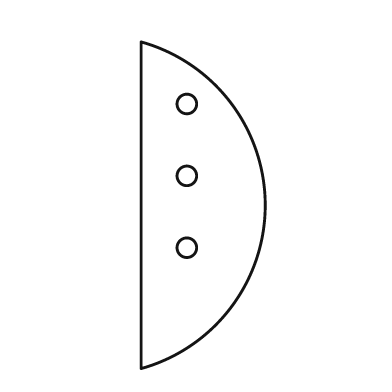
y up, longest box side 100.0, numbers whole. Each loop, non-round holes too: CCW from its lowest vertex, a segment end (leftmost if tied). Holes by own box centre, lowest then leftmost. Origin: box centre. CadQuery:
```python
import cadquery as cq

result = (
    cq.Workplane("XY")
    .moveTo(-19.0, -50.0)
    .threePointArc((19.0, 0.0), (-19.0, 50.0))
    .close()
    .moveTo(-5.0, -13.0)
    .circle(3.0)
    .moveTo(-5.0, 9.0)
    .circle(3.0)
    .moveTo(-5.0, 31.0)
    .circle(3.0)
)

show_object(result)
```